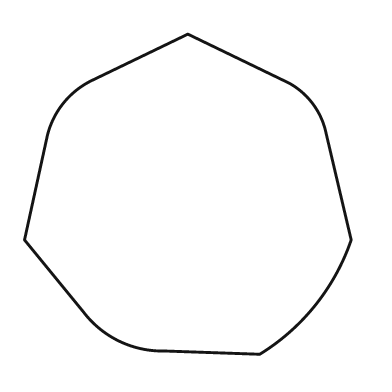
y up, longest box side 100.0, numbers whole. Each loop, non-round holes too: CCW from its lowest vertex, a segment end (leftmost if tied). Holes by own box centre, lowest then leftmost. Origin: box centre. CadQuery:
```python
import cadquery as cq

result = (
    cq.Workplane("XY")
    .moveTo(22.0, -49.0)
    .threePointArc((39.0, -34.0), (50.0, -14.0))
    .lineTo(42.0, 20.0)
    .threePointArc((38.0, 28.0), (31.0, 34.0))
    .lineTo(0.0, 49.0)
    .lineTo(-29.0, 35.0)
    .threePointArc((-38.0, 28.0), (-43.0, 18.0))
    .lineTo(-50.0, -14.0)
    .lineTo(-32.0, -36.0)
    .threePointArc((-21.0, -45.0), (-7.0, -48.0))
    .close()
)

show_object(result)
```